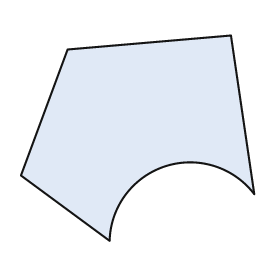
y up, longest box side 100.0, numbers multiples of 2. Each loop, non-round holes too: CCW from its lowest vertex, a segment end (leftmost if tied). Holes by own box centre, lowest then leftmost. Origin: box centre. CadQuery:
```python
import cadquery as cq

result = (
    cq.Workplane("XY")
    .moveTo(-12.0, -44.0)
    .threePointArc((12.0, -12.0), (50.0, -24.0))
    .lineTo(40.0, 44.0)
    .lineTo(-30.0, 38.0)
    .lineTo(-50.0, -16.0)
    .close()
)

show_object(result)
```